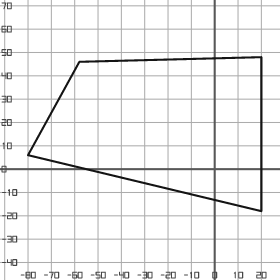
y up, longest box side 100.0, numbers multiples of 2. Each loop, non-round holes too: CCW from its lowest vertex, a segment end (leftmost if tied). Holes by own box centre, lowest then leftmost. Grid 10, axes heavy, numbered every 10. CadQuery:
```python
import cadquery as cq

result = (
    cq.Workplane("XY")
    .moveTo(20.0, -18.0)
    .lineTo(20.0, 48.0)
    .lineTo(-58.0, 46.0)
    .lineTo(-80.0, 6.0)
    .close()
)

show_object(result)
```